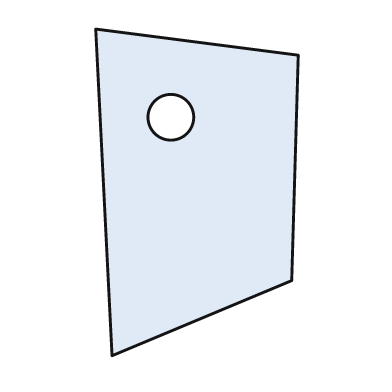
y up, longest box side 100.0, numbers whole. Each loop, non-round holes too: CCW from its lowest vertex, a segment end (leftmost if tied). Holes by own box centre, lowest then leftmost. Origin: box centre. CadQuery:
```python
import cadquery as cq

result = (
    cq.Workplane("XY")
    .moveTo(-26.0, -50.0)
    .lineTo(29.0, -27.0)
    .lineTo(31.0, 42.0)
    .lineTo(-31.0, 50.0)
    .close()
    .moveTo(-8.0, 23.0)
    .circle(7.0)
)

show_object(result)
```